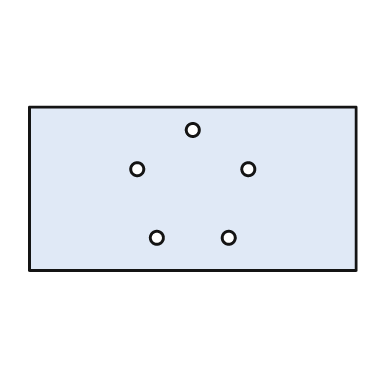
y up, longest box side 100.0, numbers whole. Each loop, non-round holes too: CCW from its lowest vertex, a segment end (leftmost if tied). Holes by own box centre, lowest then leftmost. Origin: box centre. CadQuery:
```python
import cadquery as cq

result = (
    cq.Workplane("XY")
    .moveTo(-50.0, -25.0)
    .lineTo(50.0, -25.0)
    .lineTo(50.0, 25.0)
    .lineTo(-50.0, 25.0)
    .close()
    .moveTo(-11.0, -15.0)
    .circle(2.0)
    .moveTo(11.0, -15.0)
    .circle(2.0)
    .moveTo(-17.0, 6.0)
    .circle(2.0)
    .moveTo(17.0, 6.0)
    .circle(2.0)
    .moveTo(0.0, 18.0)
    .circle(2.0)
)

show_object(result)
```